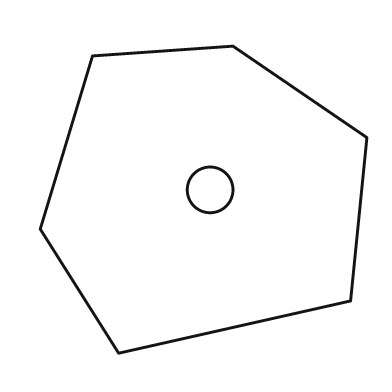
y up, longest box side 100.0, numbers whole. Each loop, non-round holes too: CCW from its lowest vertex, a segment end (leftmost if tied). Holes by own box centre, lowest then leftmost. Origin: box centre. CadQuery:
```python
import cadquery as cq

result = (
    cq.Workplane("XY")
    .moveTo(-26.0, -47.0)
    .lineTo(45.0, -31.0)
    .lineTo(50.0, 19.0)
    .lineTo(9.0, 47.0)
    .lineTo(-34.0, 44.0)
    .lineTo(-50.0, -9.0)
    .close()
    .moveTo(2.0, 3.0)
    .circle(7.0)
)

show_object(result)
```